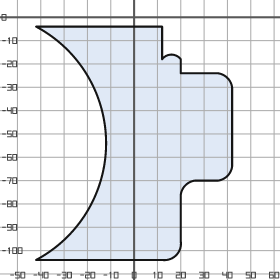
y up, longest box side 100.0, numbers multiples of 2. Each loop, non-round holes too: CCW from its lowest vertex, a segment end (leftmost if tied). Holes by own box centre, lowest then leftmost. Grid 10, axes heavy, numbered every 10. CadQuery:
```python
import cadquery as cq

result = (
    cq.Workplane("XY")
    .moveTo(-42.0, -104.0)
    .lineTo(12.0, -104.0)
    .threePointArc((18.0, -102.0), (20.0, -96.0))
    .lineTo(20.0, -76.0)
    .threePointArc((22.0, -72.0), (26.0, -70.0))
    .lineTo(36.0, -70.0)
    .threePointArc((40.0, -68.0), (42.0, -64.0))
    .lineTo(42.0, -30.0)
    .threePointArc((40.0, -26.0), (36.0, -24.0))
    .lineTo(20.0, -24.0)
    .lineTo(20.0, -18.0)
    .threePointArc((16.0, -16.0), (12.0, -18.0))
    .lineTo(12.0, -4.0)
    .lineTo(-42.0, -4.0)
    .threePointArc((-12.0, -54.0), (-42.0, -104.0))
    .close()
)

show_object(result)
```